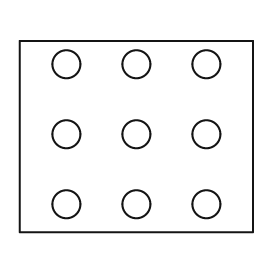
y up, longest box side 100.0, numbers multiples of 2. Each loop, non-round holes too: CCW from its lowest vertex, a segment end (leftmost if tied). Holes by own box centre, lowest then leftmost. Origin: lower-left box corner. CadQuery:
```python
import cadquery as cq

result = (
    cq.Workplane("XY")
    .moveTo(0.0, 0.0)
    .lineTo(100.0, 0.0)
    .lineTo(100.0, 82.0)
    .lineTo(0.0, 82.0)
    .close()
    .moveTo(20.0, 12.0)
    .circle(6.0)
    .moveTo(50.0, 12.0)
    .circle(6.0)
    .moveTo(80.0, 12.0)
    .circle(6.0)
    .moveTo(20.0, 42.0)
    .circle(6.0)
    .moveTo(50.0, 42.0)
    .circle(6.0)
    .moveTo(80.0, 42.0)
    .circle(6.0)
    .moveTo(20.0, 72.0)
    .circle(6.0)
    .moveTo(50.0, 72.0)
    .circle(6.0)
    .moveTo(80.0, 72.0)
    .circle(6.0)
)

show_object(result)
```